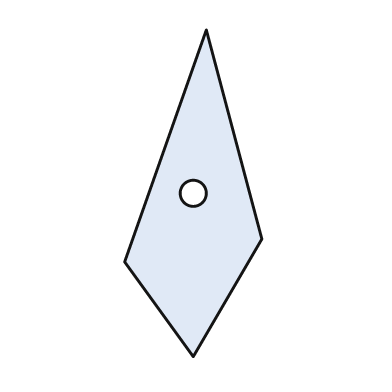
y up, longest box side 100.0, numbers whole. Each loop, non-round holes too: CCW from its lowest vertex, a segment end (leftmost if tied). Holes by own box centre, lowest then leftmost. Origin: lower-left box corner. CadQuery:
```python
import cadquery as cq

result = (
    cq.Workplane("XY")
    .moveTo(21.0, 0.0)
    .lineTo(42.0, 36.0)
    .lineTo(25.0, 100.0)
    .lineTo(0.0, 29.0)
    .close()
    .moveTo(21.0, 50.0)
    .circle(4.0)
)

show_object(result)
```